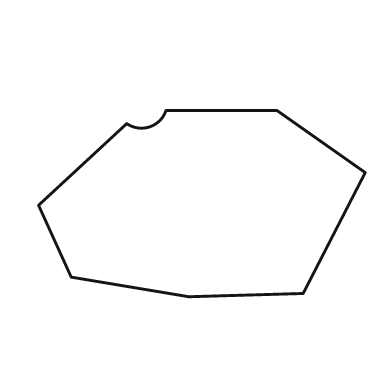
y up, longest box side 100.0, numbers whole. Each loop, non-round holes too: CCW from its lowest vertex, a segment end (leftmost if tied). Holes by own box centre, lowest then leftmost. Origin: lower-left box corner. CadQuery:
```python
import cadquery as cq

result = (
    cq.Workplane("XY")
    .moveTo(46.0, 0.0)
    .lineTo(81.0, 1.0)
    .lineTo(100.0, 38.0)
    .lineTo(73.0, 57.0)
    .lineTo(39.0, 57.0)
    .threePointArc((34.0, 52.0), (27.0, 53.0))
    .lineTo(0.0, 28.0)
    .lineTo(10.0, 6.0)
    .close()
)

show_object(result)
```